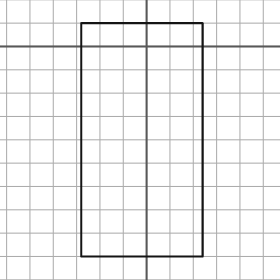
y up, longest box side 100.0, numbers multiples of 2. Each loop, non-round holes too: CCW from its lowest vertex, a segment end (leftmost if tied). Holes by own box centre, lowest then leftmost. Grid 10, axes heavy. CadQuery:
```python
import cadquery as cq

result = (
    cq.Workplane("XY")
    .moveTo(-28.0, -90.0)
    .lineTo(24.0, -90.0)
    .lineTo(24.0, 10.0)
    .lineTo(-28.0, 10.0)
    .close()
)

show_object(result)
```